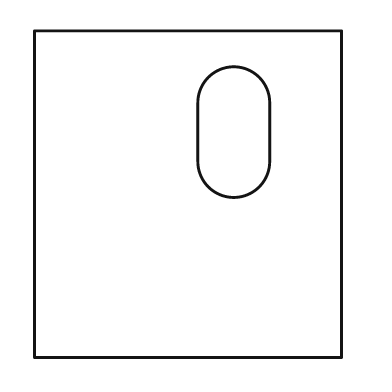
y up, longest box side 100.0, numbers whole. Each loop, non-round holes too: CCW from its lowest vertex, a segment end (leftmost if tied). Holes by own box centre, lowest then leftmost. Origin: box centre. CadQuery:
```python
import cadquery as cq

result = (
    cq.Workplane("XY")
    .moveTo(-47.0, -50.0)
    .lineTo(47.0, -50.0)
    .lineTo(47.0, 50.0)
    .lineTo(-47.0, 50.0)
    .close()
    .moveTo(3.0, 10.0)
    .threePointArc((14.0, -1.0), (25.0, 10.0))
    .lineTo(25.0, 28.0)
    .threePointArc((14.0, 39.0), (3.0, 28.0))
    .close()
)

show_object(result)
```